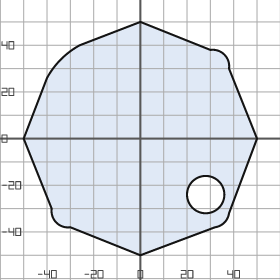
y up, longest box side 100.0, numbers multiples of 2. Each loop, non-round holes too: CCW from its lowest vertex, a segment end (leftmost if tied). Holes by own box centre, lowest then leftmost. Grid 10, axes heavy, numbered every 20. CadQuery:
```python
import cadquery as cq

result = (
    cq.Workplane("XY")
    .moveTo(0.0, -50.0)
    .lineTo(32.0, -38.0)
    .threePointArc((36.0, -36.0), (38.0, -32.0))
    .lineTo(50.0, 0.0)
    .lineTo(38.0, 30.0)
    .threePointArc((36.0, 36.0), (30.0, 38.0))
    .lineTo(0.0, 50.0)
    .lineTo(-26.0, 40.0)
    .threePointArc((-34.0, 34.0), (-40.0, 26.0))
    .lineTo(-50.0, 0.0)
    .lineTo(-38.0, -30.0)
    .threePointArc((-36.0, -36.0), (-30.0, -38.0))
    .close()
    .moveTo(28.0, -24.0)
    .circle(8.0)
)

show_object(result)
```